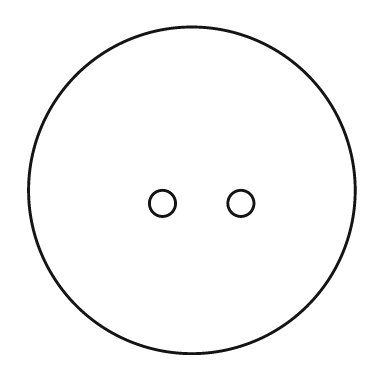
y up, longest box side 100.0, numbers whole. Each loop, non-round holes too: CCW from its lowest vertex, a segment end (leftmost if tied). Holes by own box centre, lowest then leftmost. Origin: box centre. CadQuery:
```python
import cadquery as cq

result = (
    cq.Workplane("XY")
    .moveTo(0.0, 0.0)
    .circle(50.0)
    .moveTo(-9.0, -4.0)
    .circle(4.0)
    .moveTo(15.0, -4.0)
    .circle(4.0)
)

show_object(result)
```